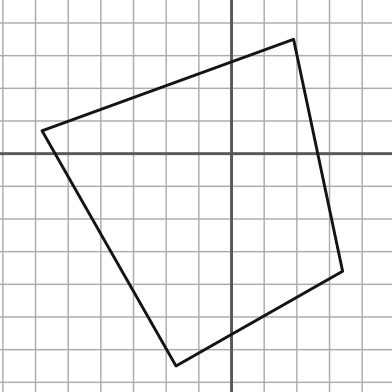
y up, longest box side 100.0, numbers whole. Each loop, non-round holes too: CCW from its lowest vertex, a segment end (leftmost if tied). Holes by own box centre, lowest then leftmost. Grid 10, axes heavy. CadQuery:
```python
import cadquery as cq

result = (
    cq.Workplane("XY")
    .moveTo(-17.0, -65.0)
    .lineTo(34.0, -36.0)
    .lineTo(19.0, 35.0)
    .lineTo(-58.0, 7.0)
    .close()
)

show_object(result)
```